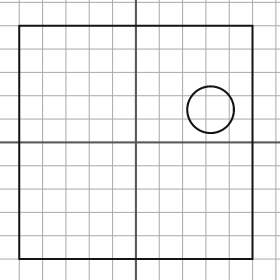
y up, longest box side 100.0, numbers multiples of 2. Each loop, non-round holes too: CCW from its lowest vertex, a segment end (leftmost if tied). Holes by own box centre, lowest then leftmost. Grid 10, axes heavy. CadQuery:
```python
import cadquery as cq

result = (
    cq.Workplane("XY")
    .moveTo(-50.0, -50.0)
    .lineTo(50.0, -50.0)
    .lineTo(50.0, 50.0)
    .lineTo(-50.0, 50.0)
    .close()
    .moveTo(32.0, 14.0)
    .circle(10.0)
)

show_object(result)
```